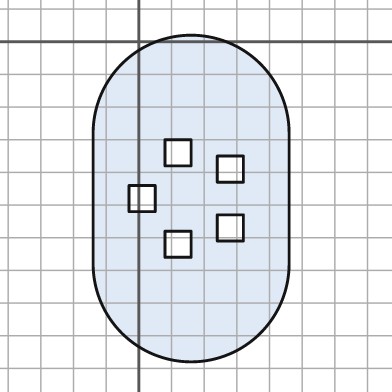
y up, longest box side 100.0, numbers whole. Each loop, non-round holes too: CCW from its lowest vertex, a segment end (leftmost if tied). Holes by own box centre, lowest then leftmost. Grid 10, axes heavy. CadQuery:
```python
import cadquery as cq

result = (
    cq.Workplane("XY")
    .moveTo(-14.0, -68.0)
    .threePointArc((16.0, -98.0), (46.0, -68.0))
    .lineTo(46.0, -28.0)
    .threePointArc((16.0, 2.0), (-14.0, -28.0))
    .close()
    .moveTo(8.0, -66.0)
    .lineTo(16.0, -66.0)
    .lineTo(16.0, -58.0)
    .lineTo(8.0, -58.0)
    .close()
    .moveTo(24.0, -61.0)
    .lineTo(32.0, -61.0)
    .lineTo(32.0, -53.0)
    .lineTo(24.0, -53.0)
    .close()
    .moveTo(-3.0, -52.0)
    .lineTo(5.0, -52.0)
    .lineTo(5.0, -44.0)
    .lineTo(-3.0, -44.0)
    .close()
    .moveTo(24.0, -43.0)
    .lineTo(32.0, -43.0)
    .lineTo(32.0, -35.0)
    .lineTo(24.0, -35.0)
    .close()
    .moveTo(8.0, -38.0)
    .lineTo(16.0, -38.0)
    .lineTo(16.0, -30.0)
    .lineTo(8.0, -30.0)
    .close()
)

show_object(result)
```